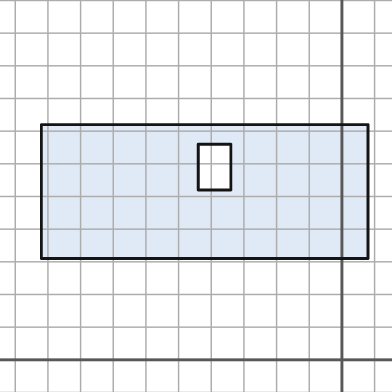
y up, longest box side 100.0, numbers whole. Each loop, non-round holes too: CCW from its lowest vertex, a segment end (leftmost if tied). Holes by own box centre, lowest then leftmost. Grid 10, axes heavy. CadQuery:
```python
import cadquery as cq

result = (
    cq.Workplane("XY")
    .moveTo(-92.0, 31.0)
    .lineTo(8.0, 31.0)
    .lineTo(8.0, 72.0)
    .lineTo(-92.0, 72.0)
    .close()
    .moveTo(-44.0, 52.0)
    .lineTo(-34.0, 52.0)
    .lineTo(-34.0, 66.0)
    .lineTo(-44.0, 66.0)
    .close()
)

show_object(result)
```